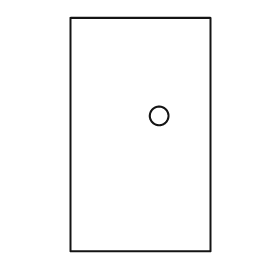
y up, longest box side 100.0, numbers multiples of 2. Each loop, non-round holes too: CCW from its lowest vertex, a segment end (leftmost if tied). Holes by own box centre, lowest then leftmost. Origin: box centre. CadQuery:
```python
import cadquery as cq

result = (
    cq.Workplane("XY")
    .moveTo(-30.0, -50.0)
    .lineTo(30.0, -50.0)
    .lineTo(30.0, 50.0)
    .lineTo(-30.0, 50.0)
    .close()
    .moveTo(8.0, 8.0)
    .circle(4.0)
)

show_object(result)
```